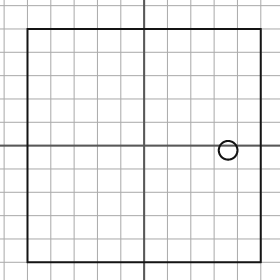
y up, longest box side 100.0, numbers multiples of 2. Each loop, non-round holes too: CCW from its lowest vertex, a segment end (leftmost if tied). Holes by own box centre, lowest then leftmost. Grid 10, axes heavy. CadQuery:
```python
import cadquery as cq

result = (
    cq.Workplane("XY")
    .moveTo(-50.0, -50.0)
    .lineTo(50.0, -50.0)
    .lineTo(50.0, 50.0)
    .lineTo(-50.0, 50.0)
    .close()
    .moveTo(36.0, -2.0)
    .circle(4.0)
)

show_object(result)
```